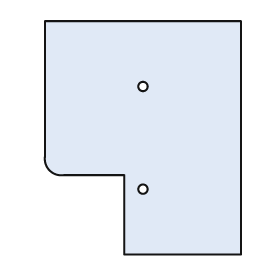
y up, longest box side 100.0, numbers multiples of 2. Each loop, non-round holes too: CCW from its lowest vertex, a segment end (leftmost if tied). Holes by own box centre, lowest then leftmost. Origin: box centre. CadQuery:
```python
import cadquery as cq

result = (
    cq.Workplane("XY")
    .moveTo(-8.0, -50.0)
    .lineTo(42.0, -50.0)
    .lineTo(42.0, 50.0)
    .lineTo(-42.0, 50.0)
    .lineTo(-42.0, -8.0)
    .threePointArc((-40.0, -14.0), (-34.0, -16.0))
    .lineTo(-8.0, -16.0)
    .close()
    .moveTo(0.0, -22.0)
    .circle(2.0)
    .moveTo(0.0, 22.0)
    .circle(2.0)
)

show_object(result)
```